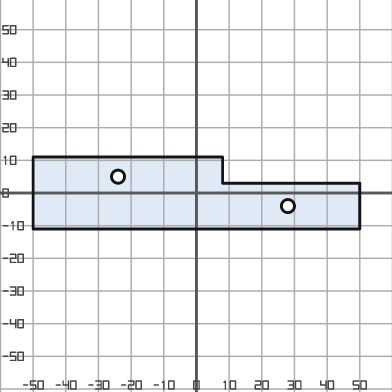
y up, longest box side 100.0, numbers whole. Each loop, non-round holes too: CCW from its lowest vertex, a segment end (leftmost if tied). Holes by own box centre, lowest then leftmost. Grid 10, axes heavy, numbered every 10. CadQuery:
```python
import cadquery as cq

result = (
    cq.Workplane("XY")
    .moveTo(-50.0, -11.0)
    .lineTo(50.0, -11.0)
    .lineTo(50.0, 3.0)
    .lineTo(8.0, 3.0)
    .lineTo(8.0, 11.0)
    .lineTo(-50.0, 11.0)
    .close()
    .moveTo(28.0, -4.0)
    .circle(2.0)
    .moveTo(-24.0, 5.0)
    .circle(2.0)
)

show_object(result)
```